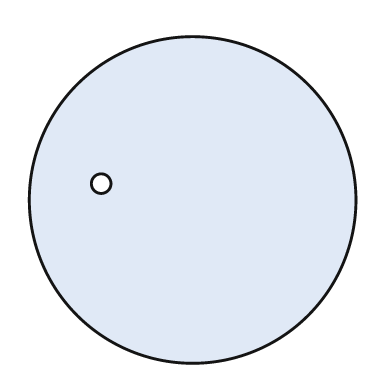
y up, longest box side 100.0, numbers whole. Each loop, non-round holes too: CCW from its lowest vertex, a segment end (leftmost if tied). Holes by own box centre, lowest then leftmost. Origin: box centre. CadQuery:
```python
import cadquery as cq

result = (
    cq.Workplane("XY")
    .moveTo(0.0, 0.0)
    .circle(50.0)
    .moveTo(-28.0, 5.0)
    .circle(3.0)
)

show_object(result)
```